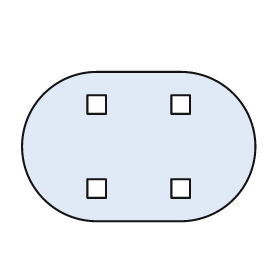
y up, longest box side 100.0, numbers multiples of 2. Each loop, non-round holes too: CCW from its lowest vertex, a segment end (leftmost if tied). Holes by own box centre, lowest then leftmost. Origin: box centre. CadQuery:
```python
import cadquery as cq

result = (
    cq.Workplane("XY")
    .moveTo(-18.0, -32.0)
    .lineTo(18.0, -32.0)
    .threePointArc((50.0, 0.0), (18.0, 32.0))
    .lineTo(-18.0, 32.0)
    .threePointArc((-50.0, 0.0), (-18.0, -32.0))
    .close()
    .moveTo(-22.0, -22.0)
    .lineTo(-14.0, -22.0)
    .lineTo(-14.0, -14.0)
    .lineTo(-22.0, -14.0)
    .close()
    .moveTo(14.0, -22.0)
    .lineTo(22.0, -22.0)
    .lineTo(22.0, -14.0)
    .lineTo(14.0, -14.0)
    .close()
    .moveTo(-22.0, 14.0)
    .lineTo(-14.0, 14.0)
    .lineTo(-14.0, 22.0)
    .lineTo(-22.0, 22.0)
    .close()
    .moveTo(14.0, 14.0)
    .lineTo(22.0, 14.0)
    .lineTo(22.0, 22.0)
    .lineTo(14.0, 22.0)
    .close()
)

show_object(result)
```